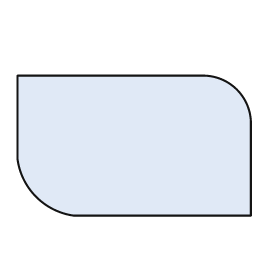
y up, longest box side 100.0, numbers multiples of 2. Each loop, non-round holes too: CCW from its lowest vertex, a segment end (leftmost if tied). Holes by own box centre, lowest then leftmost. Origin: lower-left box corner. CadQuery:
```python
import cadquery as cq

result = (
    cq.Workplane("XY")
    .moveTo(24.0, 0.0)
    .lineTo(100.0, 0.0)
    .lineTo(100.0, 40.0)
    .threePointArc((94.0, 54.0), (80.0, 60.0))
    .lineTo(0.0, 60.0)
    .lineTo(0.0, 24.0)
    .threePointArc((8.0, 8.0), (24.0, 0.0))
    .close()
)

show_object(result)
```